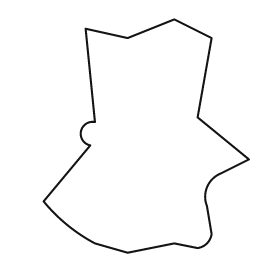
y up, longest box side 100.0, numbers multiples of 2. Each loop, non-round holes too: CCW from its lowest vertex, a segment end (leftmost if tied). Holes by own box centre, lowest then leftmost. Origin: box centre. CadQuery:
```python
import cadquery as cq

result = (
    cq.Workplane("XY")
    .moveTo(-8.0, -50.0)
    .lineTo(12.0, -46.0)
    .lineTo(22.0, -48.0)
    .threePointArc((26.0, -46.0), (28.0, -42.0))
    .lineTo(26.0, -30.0)
    .threePointArc((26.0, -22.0), (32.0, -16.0))
    .lineTo(44.0, -10.0)
    .lineTo(22.0, 8.0)
    .lineTo(28.0, 42.0)
    .lineTo(12.0, 50.0)
    .lineTo(-8.0, 42.0)
    .lineTo(-26.0, 46.0)
    .lineTo(-22.0, 6.0)
    .threePointArc((-28.0, 2.0), (-24.0, -4.0))
    .lineTo(-44.0, -28.0)
    .threePointArc((-34.0, -38.0), (-22.0, -46.0))
    .close()
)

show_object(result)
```